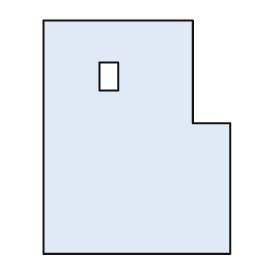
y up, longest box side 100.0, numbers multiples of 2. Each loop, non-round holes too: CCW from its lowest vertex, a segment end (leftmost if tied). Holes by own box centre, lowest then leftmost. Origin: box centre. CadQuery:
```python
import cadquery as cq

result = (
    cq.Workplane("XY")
    .moveTo(-40.0, -50.0)
    .lineTo(40.0, -50.0)
    .lineTo(40.0, 6.0)
    .lineTo(24.0, 6.0)
    .lineTo(24.0, 50.0)
    .lineTo(-40.0, 50.0)
    .close()
    .moveTo(-16.0, 20.0)
    .lineTo(-8.0, 20.0)
    .lineTo(-8.0, 32.0)
    .lineTo(-16.0, 32.0)
    .close()
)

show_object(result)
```